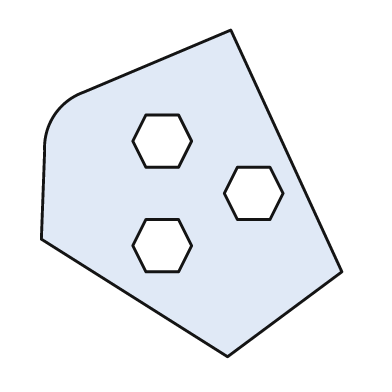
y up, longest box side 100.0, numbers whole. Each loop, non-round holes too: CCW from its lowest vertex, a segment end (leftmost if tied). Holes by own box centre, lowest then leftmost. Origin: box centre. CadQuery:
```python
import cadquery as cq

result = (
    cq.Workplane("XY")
    .moveTo(11.0, -50.0)
    .lineTo(46.0, -24.0)
    .lineTo(12.0, 50.0)
    .lineTo(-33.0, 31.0)
    .threePointArc((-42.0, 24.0), (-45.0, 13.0))
    .lineTo(-46.0, -14.0)
    .close()
    .moveTo(-14.0, -24.0)
    .lineTo(-4.0, -24.0)
    .lineTo(0.0, -16.0)
    .lineTo(-4.0, -8.0)
    .lineTo(-14.0, -8.0)
    .lineTo(-18.0, -16.0)
    .close()
    .moveTo(14.0, -8.0)
    .lineTo(24.0, -8.0)
    .lineTo(28.0, 0.0)
    .lineTo(24.0, 8.0)
    .lineTo(14.0, 8.0)
    .lineTo(10.0, 0.0)
    .close()
    .moveTo(-14.0, 8.0)
    .lineTo(-4.0, 8.0)
    .lineTo(0.0, 16.0)
    .lineTo(-4.0, 24.0)
    .lineTo(-14.0, 24.0)
    .lineTo(-18.0, 16.0)
    .close()
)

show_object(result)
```